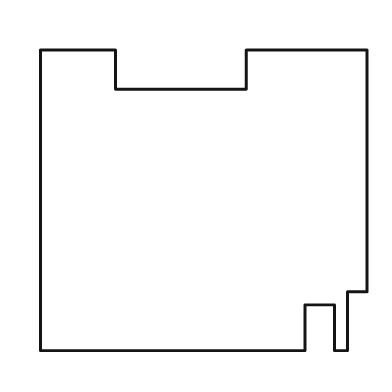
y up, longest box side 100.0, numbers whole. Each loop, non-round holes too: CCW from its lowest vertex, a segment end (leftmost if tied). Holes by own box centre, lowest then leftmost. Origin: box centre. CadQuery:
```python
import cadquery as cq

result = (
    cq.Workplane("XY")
    .moveTo(-50.0, -46.0)
    .lineTo(31.0, -46.0)
    .lineTo(31.0, -32.0)
    .lineTo(40.0, -32.0)
    .lineTo(40.0, -46.0)
    .lineTo(44.0, -46.0)
    .lineTo(44.0, -28.0)
    .lineTo(50.0, -28.0)
    .lineTo(50.0, 46.0)
    .lineTo(13.0, 46.0)
    .lineTo(13.0, 34.0)
    .lineTo(-27.0, 34.0)
    .lineTo(-27.0, 46.0)
    .lineTo(-50.0, 46.0)
    .close()
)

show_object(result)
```